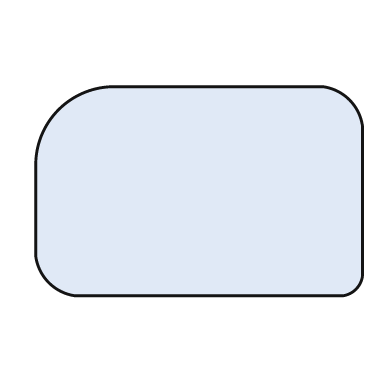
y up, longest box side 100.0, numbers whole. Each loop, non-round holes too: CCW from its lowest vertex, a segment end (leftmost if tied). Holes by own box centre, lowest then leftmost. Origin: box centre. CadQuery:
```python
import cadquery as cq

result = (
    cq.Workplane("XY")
    .moveTo(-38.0, -32.0)
    .lineTo(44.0, -32.0)
    .threePointArc((48.0, -30.0), (50.0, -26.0))
    .lineTo(50.0, 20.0)
    .threePointArc((46.0, 28.0), (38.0, 32.0))
    .lineTo(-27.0, 32.0)
    .threePointArc((-43.0, 25.0), (-50.0, 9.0))
    .lineTo(-50.0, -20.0)
    .threePointArc((-46.0, -28.0), (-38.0, -32.0))
    .close()
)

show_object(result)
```